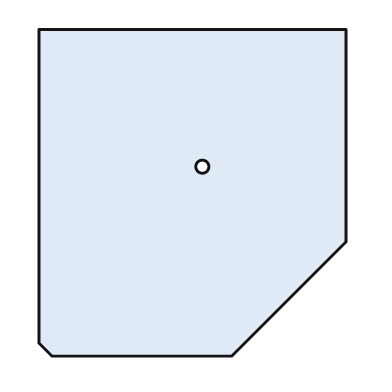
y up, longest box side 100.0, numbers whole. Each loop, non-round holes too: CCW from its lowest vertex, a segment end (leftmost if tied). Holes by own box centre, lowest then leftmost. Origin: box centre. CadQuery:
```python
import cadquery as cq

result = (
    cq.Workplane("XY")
    .moveTo(-43.0, -50.0)
    .lineTo(12.0, -50.0)
    .lineTo(47.0, -15.0)
    .lineTo(47.0, 50.0)
    .lineTo(-47.0, 50.0)
    .lineTo(-47.0, -46.0)
    .close()
    .moveTo(3.0, 8.0)
    .circle(2.0)
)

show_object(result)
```